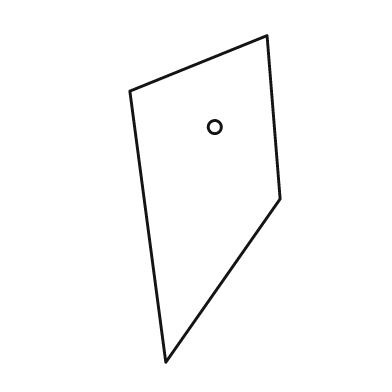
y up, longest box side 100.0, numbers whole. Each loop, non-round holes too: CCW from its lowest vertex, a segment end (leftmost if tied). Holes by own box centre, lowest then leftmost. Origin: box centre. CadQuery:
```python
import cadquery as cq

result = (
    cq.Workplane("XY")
    .moveTo(-12.0, -50.0)
    .lineTo(23.0, 0.0)
    .lineTo(19.0, 50.0)
    .lineTo(-23.0, 33.0)
    .close()
    .moveTo(3.0, 22.0)
    .circle(2.0)
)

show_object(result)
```